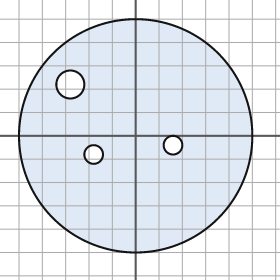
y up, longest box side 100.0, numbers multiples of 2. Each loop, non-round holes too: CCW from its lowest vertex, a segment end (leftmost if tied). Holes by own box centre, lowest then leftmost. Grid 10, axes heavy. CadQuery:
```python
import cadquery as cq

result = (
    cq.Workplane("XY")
    .moveTo(0.0, 0.0)
    .circle(50.0)
    .moveTo(-18.0, -8.0)
    .circle(4.0)
    .moveTo(16.0, -4.0)
    .circle(4.0)
    .moveTo(-28.0, 22.0)
    .circle(6.0)
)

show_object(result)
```